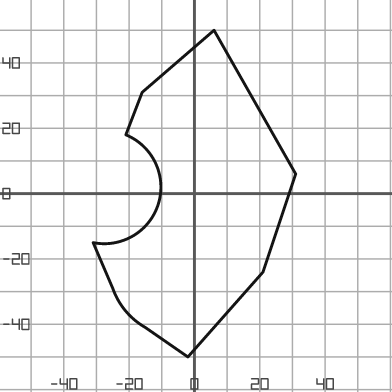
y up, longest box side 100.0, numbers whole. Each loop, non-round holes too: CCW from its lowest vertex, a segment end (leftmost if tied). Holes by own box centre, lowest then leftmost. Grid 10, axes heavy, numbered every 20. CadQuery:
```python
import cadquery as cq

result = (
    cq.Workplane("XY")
    .moveTo(-2.0, -50.0)
    .lineTo(21.0, -24.0)
    .lineTo(31.0, 6.0)
    .lineTo(6.0, 50.0)
    .lineTo(-16.0, 31.0)
    .lineTo(-21.0, 18.0)
    .threePointArc((-11.0, -3.0), (-31.0, -15.0))
    .lineTo(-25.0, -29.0)
    .threePointArc((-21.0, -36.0), (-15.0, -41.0))
    .close()
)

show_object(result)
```